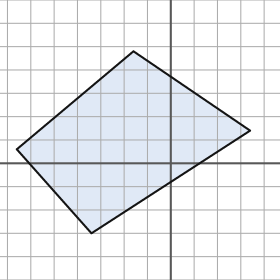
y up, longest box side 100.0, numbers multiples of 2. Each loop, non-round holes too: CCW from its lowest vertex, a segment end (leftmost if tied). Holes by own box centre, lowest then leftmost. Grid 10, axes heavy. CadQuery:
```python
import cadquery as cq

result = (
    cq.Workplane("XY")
    .moveTo(-34.0, -30.0)
    .lineTo(34.0, 14.0)
    .lineTo(-16.0, 48.0)
    .lineTo(-66.0, 6.0)
    .close()
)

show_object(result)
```